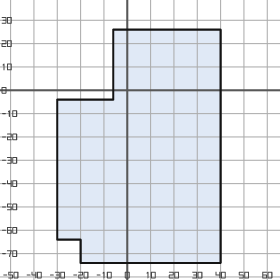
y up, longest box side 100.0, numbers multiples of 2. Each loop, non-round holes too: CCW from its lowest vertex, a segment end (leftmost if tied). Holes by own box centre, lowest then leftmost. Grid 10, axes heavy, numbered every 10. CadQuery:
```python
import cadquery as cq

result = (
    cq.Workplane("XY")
    .moveTo(-20.0, -74.0)
    .lineTo(40.0, -74.0)
    .lineTo(40.0, 26.0)
    .lineTo(-6.0, 26.0)
    .lineTo(-6.0, -4.0)
    .lineTo(-30.0, -4.0)
    .lineTo(-30.0, -64.0)
    .lineTo(-20.0, -64.0)
    .close()
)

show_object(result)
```